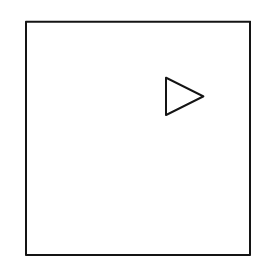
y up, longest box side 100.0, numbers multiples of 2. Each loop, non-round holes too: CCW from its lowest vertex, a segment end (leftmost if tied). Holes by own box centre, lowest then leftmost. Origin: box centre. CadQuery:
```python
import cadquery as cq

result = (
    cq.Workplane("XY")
    .moveTo(-48.0, -50.0)
    .lineTo(48.0, -50.0)
    .lineTo(48.0, 50.0)
    .lineTo(-48.0, 50.0)
    .close()
    .moveTo(12.0, 10.0)
    .lineTo(28.0, 18.0)
    .lineTo(12.0, 26.0)
    .close()
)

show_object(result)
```